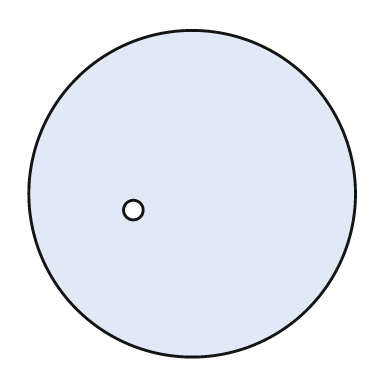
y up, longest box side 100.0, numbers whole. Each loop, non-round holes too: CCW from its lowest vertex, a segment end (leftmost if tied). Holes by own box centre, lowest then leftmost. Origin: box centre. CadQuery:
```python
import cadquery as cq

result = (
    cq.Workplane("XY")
    .moveTo(0.0, 0.0)
    .circle(50.0)
    .moveTo(-18.0, -5.0)
    .circle(3.0)
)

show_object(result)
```